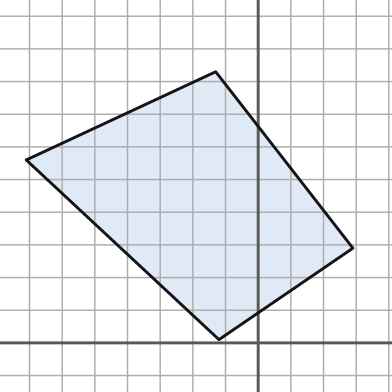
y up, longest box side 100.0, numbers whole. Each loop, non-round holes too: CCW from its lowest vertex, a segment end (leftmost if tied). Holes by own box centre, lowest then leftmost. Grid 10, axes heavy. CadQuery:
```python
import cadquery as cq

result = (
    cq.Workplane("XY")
    .moveTo(-12.0, 1.0)
    .lineTo(29.0, 29.0)
    .lineTo(-13.0, 83.0)
    .lineTo(-71.0, 56.0)
    .close()
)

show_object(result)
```